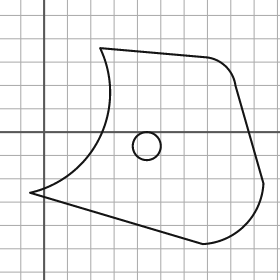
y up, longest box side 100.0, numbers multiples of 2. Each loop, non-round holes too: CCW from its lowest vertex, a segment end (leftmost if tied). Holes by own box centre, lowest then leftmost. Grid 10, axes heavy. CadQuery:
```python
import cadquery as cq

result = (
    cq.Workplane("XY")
    .moveTo(68.0, -48.0)
    .threePointArc((86.0, -40.0), (94.0, -22.0))
    .lineTo(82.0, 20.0)
    .threePointArc((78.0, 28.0), (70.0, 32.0))
    .lineTo(24.0, 36.0)
    .threePointArc((24.0, -2.0), (-6.0, -26.0))
    .close()
    .moveTo(44.0, -6.0)
    .circle(6.0)
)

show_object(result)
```